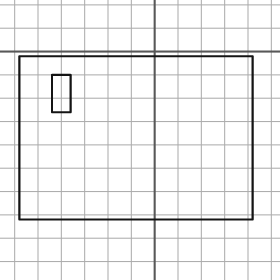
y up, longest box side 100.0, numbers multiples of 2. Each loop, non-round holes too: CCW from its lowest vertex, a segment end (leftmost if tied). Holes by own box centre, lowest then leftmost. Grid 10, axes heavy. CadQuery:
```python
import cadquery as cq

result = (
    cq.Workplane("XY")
    .moveTo(-58.0, -72.0)
    .lineTo(42.0, -72.0)
    .lineTo(42.0, -2.0)
    .lineTo(-58.0, -2.0)
    .close()
    .moveTo(-44.0, -26.0)
    .lineTo(-36.0, -26.0)
    .lineTo(-36.0, -10.0)
    .lineTo(-44.0, -10.0)
    .close()
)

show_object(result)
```